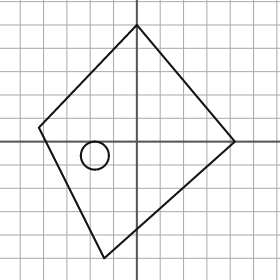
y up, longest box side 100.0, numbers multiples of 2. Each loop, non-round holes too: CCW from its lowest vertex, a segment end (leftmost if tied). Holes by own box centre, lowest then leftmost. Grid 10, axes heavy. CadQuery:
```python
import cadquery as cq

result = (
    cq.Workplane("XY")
    .moveTo(-14.0, -50.0)
    .lineTo(42.0, 0.0)
    .lineTo(0.0, 50.0)
    .lineTo(-42.0, 6.0)
    .close()
    .moveTo(-18.0, -6.0)
    .circle(6.0)
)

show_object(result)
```